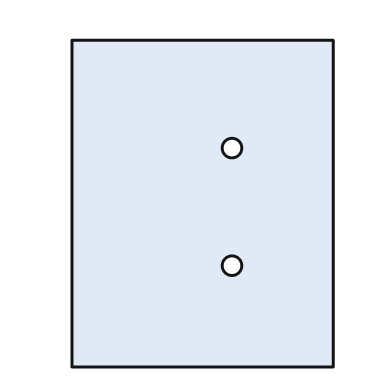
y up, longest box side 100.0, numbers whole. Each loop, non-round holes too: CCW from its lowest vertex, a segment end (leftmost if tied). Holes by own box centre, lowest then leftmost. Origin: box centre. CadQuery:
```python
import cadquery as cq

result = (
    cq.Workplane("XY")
    .moveTo(-40.0, -50.0)
    .lineTo(40.0, -50.0)
    .lineTo(40.0, 50.0)
    .lineTo(-40.0, 50.0)
    .close()
    .moveTo(9.0, -19.0)
    .circle(3.0)
    .moveTo(9.0, 17.0)
    .circle(3.0)
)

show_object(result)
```